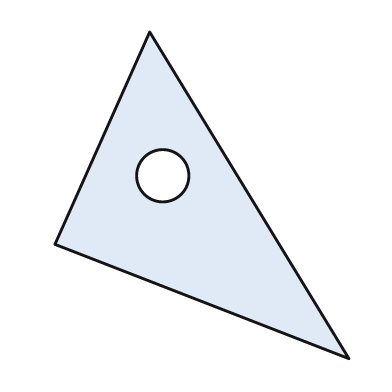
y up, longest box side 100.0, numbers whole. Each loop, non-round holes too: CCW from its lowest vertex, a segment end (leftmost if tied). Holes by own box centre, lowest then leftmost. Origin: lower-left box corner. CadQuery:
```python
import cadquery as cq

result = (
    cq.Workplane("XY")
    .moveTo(90.0, 0.0)
    .lineTo(29.0, 100.0)
    .lineTo(0.0, 35.0)
    .close()
    .moveTo(33.0, 56.0)
    .circle(8.0)
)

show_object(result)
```